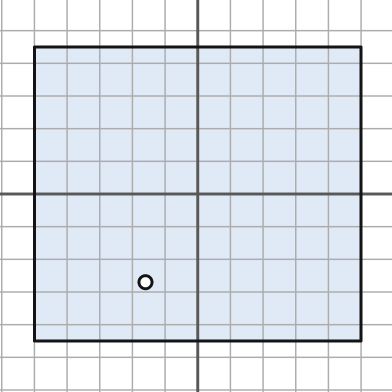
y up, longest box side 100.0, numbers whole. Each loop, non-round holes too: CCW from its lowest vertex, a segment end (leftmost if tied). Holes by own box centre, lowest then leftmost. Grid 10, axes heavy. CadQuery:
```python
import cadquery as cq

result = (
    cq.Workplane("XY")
    .moveTo(-50.0, -45.0)
    .lineTo(50.0, -45.0)
    .lineTo(50.0, 45.0)
    .lineTo(-50.0, 45.0)
    .close()
    .moveTo(-16.0, -27.0)
    .circle(2.0)
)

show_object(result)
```